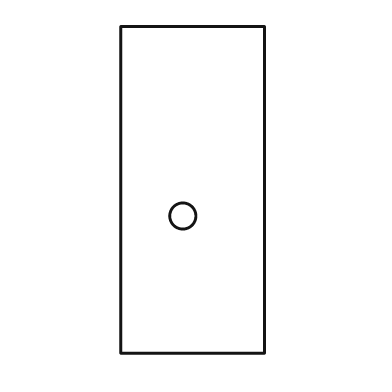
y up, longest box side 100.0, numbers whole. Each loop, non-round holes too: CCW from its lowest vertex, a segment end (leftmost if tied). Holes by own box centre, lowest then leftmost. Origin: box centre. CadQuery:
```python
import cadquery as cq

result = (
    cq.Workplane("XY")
    .moveTo(-22.0, -50.0)
    .lineTo(22.0, -50.0)
    .lineTo(22.0, 50.0)
    .lineTo(-22.0, 50.0)
    .close()
    .moveTo(-3.0, -8.0)
    .circle(4.0)
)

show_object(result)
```